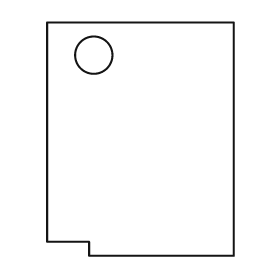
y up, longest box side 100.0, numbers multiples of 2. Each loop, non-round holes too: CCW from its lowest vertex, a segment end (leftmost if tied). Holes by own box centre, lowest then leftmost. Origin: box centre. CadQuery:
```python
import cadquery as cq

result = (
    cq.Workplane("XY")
    .moveTo(-22.0, -50.0)
    .lineTo(40.0, -50.0)
    .lineTo(40.0, 50.0)
    .lineTo(-40.0, 50.0)
    .lineTo(-40.0, -44.0)
    .lineTo(-22.0, -44.0)
    .close()
    .moveTo(-20.0, 36.0)
    .circle(8.0)
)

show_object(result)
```